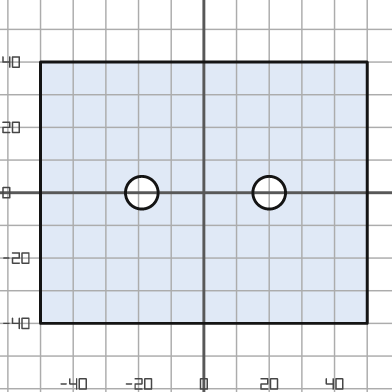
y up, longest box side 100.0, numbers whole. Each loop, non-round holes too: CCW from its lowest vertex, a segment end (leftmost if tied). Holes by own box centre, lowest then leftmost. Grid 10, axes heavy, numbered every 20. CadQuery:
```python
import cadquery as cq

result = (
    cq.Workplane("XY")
    .moveTo(-50.0, -40.0)
    .lineTo(50.0, -40.0)
    .lineTo(50.0, 40.0)
    .lineTo(-50.0, 40.0)
    .close()
    .moveTo(-19.0, 0.0)
    .circle(5.0)
    .moveTo(20.0, 0.0)
    .circle(5.0)
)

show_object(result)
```